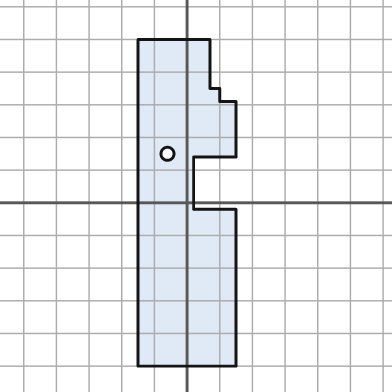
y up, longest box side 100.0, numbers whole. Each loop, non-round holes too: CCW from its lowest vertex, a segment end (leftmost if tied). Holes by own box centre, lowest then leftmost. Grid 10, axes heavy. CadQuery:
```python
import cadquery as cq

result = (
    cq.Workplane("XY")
    .moveTo(-15.0, -50.0)
    .lineTo(15.0, -50.0)
    .lineTo(15.0, -2.0)
    .lineTo(2.0, -2.0)
    .lineTo(2.0, 14.0)
    .lineTo(15.0, 14.0)
    .lineTo(15.0, 31.0)
    .lineTo(10.0, 31.0)
    .lineTo(10.0, 35.0)
    .lineTo(7.0, 35.0)
    .lineTo(7.0, 50.0)
    .lineTo(-15.0, 50.0)
    .close()
    .moveTo(-6.0, 15.0)
    .circle(2.0)
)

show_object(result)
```